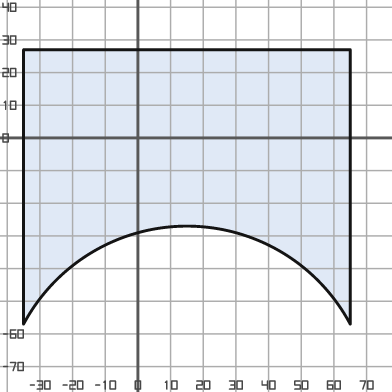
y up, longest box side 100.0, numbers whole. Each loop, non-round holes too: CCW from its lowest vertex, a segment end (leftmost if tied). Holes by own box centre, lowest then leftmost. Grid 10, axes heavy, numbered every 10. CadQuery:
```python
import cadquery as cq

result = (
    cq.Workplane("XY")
    .moveTo(-35.0, -57.0)
    .threePointArc((15.0, -27.0), (65.0, -57.0))
    .lineTo(65.0, 27.0)
    .lineTo(-35.0, 27.0)
    .close()
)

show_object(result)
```